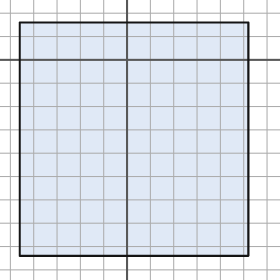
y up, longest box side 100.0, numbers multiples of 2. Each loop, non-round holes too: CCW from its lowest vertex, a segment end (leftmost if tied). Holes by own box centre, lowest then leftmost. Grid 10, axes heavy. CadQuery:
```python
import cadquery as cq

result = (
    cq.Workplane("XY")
    .moveTo(-46.0, -84.0)
    .lineTo(52.0, -84.0)
    .lineTo(52.0, 16.0)
    .lineTo(-46.0, 16.0)
    .close()
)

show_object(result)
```